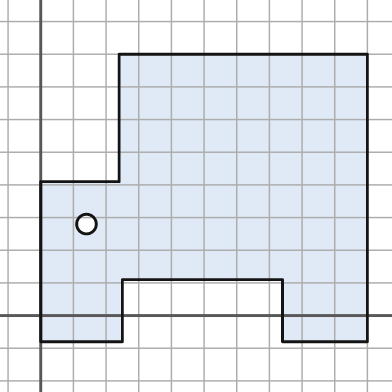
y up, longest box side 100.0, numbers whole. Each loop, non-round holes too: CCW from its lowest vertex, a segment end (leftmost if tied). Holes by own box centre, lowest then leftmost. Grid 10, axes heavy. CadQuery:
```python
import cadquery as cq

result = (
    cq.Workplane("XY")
    .moveTo(0.0, -8.0)
    .lineTo(25.0, -8.0)
    .lineTo(25.0, 11.0)
    .lineTo(74.0, 11.0)
    .lineTo(74.0, -8.0)
    .lineTo(100.0, -8.0)
    .lineTo(100.0, 80.0)
    .lineTo(24.0, 80.0)
    .lineTo(24.0, 41.0)
    .lineTo(0.0, 41.0)
    .close()
    .moveTo(14.0, 28.0)
    .circle(3.0)
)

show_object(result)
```